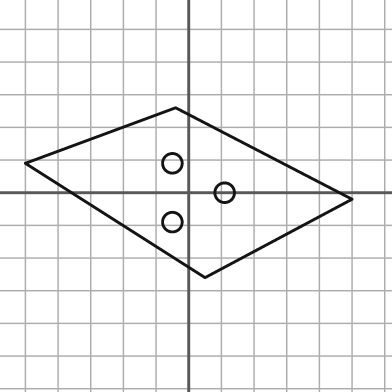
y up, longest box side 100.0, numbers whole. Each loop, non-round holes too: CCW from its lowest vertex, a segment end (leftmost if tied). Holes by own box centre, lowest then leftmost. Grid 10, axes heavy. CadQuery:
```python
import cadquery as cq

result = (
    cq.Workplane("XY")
    .moveTo(5.0, -26.0)
    .lineTo(50.0, -2.0)
    .lineTo(-4.0, 26.0)
    .lineTo(-50.0, 9.0)
    .close()
    .moveTo(-5.0, -9.0)
    .circle(3.0)
    .moveTo(11.0, 0.0)
    .circle(3.0)
    .moveTo(-5.0, 9.0)
    .circle(3.0)
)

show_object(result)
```